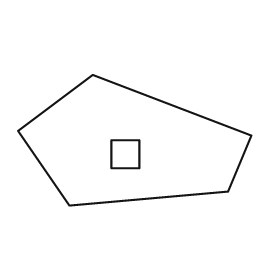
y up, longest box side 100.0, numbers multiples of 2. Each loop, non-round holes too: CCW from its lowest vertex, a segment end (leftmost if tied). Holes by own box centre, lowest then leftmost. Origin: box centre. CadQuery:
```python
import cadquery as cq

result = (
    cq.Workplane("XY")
    .moveTo(-28.0, -28.0)
    .lineTo(40.0, -22.0)
    .lineTo(50.0, 2.0)
    .lineTo(-18.0, 28.0)
    .lineTo(-50.0, 4.0)
    .close()
    .moveTo(-10.0, -12.0)
    .lineTo(2.0, -12.0)
    .lineTo(2.0, 0.0)
    .lineTo(-10.0, 0.0)
    .close()
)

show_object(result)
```